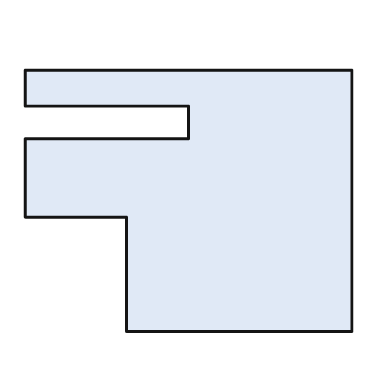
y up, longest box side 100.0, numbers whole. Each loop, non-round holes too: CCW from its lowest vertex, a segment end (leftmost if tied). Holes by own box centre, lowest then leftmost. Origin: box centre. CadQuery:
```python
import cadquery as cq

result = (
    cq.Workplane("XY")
    .moveTo(-19.0, -40.0)
    .lineTo(50.0, -40.0)
    .lineTo(50.0, 40.0)
    .lineTo(-50.0, 40.0)
    .lineTo(-50.0, 29.0)
    .lineTo(0.0, 29.0)
    .lineTo(0.0, 19.0)
    .lineTo(-50.0, 19.0)
    .lineTo(-50.0, -5.0)
    .lineTo(-19.0, -5.0)
    .close()
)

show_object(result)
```